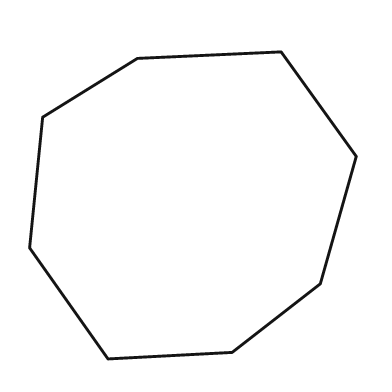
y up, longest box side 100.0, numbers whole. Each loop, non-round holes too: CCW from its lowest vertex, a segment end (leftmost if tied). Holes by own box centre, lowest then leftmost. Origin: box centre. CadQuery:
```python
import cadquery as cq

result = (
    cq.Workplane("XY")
    .moveTo(-26.0, -47.0)
    .lineTo(12.0, -45.0)
    .lineTo(39.0, -24.0)
    .lineTo(50.0, 15.0)
    .lineTo(27.0, 47.0)
    .lineTo(-17.0, 45.0)
    .lineTo(-46.0, 27.0)
    .lineTo(-50.0, -13.0)
    .close()
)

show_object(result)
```